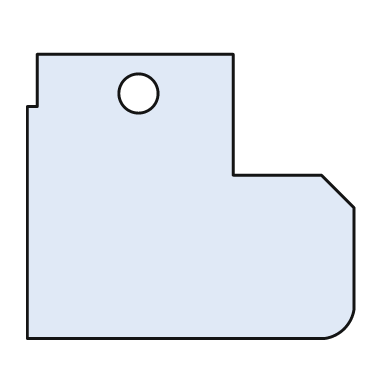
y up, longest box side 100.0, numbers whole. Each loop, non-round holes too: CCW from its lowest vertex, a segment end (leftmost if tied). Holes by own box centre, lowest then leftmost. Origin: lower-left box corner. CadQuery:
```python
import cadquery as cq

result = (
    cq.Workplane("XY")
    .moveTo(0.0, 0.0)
    .lineTo(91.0, 0.0)
    .threePointArc((97.0, 3.0), (100.0, 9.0))
    .lineTo(100.0, 40.0)
    .lineTo(90.0, 50.0)
    .lineTo(63.0, 50.0)
    .lineTo(63.0, 87.0)
    .lineTo(3.0, 87.0)
    .lineTo(3.0, 71.0)
    .lineTo(0.0, 71.0)
    .close()
    .moveTo(34.0, 75.0)
    .circle(6.0)
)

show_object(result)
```